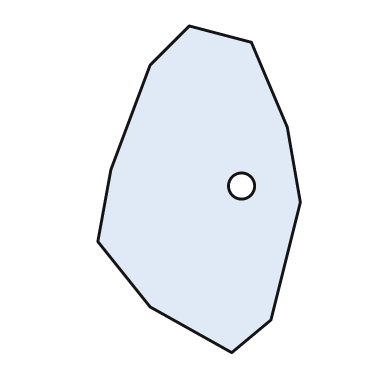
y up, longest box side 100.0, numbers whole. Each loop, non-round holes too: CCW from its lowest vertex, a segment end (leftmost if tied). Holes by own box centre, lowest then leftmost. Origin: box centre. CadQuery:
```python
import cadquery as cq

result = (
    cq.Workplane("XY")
    .moveTo(10.0, -50.0)
    .lineTo(22.0, -40.0)
    .lineTo(31.0, -4.0)
    .lineTo(27.0, 19.0)
    .lineTo(16.0, 45.0)
    .lineTo(-3.0, 50.0)
    .lineTo(-15.0, 38.0)
    .lineTo(-27.0, 6.0)
    .lineTo(-31.0, -16.0)
    .lineTo(-15.0, -36.0)
    .close()
    .moveTo(13.0, 1.0)
    .circle(4.0)
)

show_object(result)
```